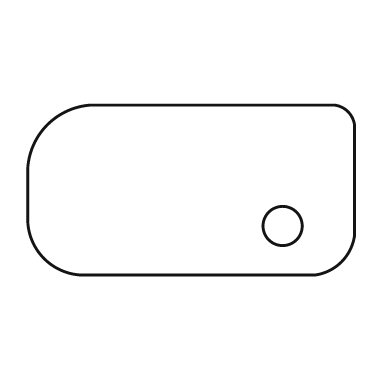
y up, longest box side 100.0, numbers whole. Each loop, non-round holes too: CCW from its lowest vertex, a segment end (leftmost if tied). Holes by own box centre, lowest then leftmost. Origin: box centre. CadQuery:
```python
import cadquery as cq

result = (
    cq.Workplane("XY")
    .moveTo(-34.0, -26.0)
    .lineTo(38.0, -26.0)
    .threePointArc((46.0, -22.0), (50.0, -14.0))
    .lineTo(50.0, 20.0)
    .threePointArc((48.0, 24.0), (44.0, 26.0))
    .lineTo(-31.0, 26.0)
    .threePointArc((-44.0, 20.0), (-50.0, 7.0))
    .lineTo(-50.0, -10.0)
    .threePointArc((-45.0, -21.0), (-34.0, -26.0))
    .close()
    .moveTo(28.0, -11.0)
    .circle(6.0)
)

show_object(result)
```